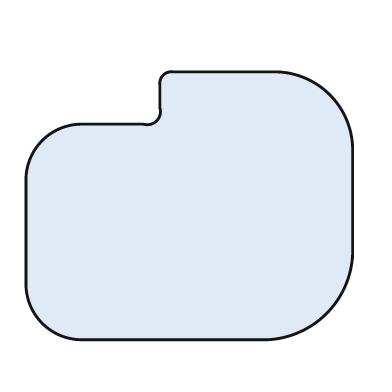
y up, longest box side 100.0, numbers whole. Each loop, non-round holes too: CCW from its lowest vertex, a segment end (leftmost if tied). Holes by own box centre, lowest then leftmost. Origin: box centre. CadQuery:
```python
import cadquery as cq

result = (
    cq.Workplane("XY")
    .moveTo(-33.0, -41.0)
    .lineTo(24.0, -41.0)
    .threePointArc((42.0, -33.0), (50.0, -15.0))
    .lineTo(50.0, 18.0)
    .threePointArc((43.0, 34.0), (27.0, 41.0))
    .lineTo(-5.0, 41.0)
    .threePointArc((-8.0, 40.0), (-9.0, 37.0))
    .lineTo(-9.0, 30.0)
    .threePointArc((-10.0, 26.0), (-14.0, 25.0))
    .lineTo(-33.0, 25.0)
    .threePointArc((-45.0, 20.0), (-50.0, 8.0))
    .lineTo(-50.0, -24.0)
    .threePointArc((-45.0, -36.0), (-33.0, -41.0))
    .close()
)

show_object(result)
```